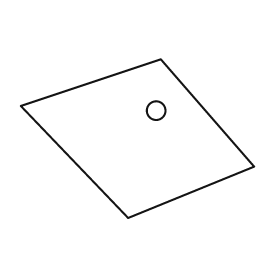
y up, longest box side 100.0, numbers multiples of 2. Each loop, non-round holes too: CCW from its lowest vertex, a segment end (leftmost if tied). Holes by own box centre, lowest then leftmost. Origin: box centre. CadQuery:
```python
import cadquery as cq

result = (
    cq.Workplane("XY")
    .moveTo(-4.0, -34.0)
    .lineTo(50.0, -12.0)
    .lineTo(10.0, 34.0)
    .lineTo(-50.0, 14.0)
    .close()
    .moveTo(8.0, 12.0)
    .circle(4.0)
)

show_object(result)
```